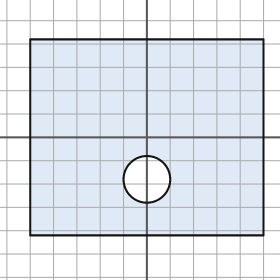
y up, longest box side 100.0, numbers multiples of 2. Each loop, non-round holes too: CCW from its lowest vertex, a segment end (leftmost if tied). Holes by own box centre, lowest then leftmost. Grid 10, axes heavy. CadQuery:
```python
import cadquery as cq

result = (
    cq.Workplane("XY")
    .moveTo(-50.0, -42.0)
    .lineTo(50.0, -42.0)
    .lineTo(50.0, 42.0)
    .lineTo(-50.0, 42.0)
    .close()
    .moveTo(0.0, -18.0)
    .circle(10.0)
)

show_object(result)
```